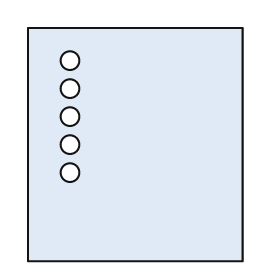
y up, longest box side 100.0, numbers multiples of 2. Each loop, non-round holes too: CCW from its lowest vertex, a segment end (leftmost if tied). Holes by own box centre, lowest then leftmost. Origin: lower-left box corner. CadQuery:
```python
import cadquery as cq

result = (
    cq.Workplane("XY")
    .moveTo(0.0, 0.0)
    .lineTo(92.0, 0.0)
    .lineTo(92.0, 100.0)
    .lineTo(0.0, 100.0)
    .close()
    .moveTo(18.0, 38.0)
    .circle(4.0)
    .moveTo(18.0, 50.0)
    .circle(4.0)
    .moveTo(18.0, 62.0)
    .circle(4.0)
    .moveTo(18.0, 74.0)
    .circle(4.0)
    .moveTo(18.0, 86.0)
    .circle(4.0)
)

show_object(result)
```